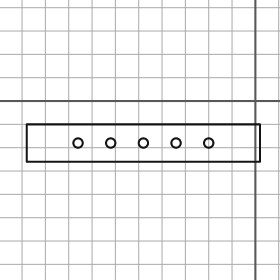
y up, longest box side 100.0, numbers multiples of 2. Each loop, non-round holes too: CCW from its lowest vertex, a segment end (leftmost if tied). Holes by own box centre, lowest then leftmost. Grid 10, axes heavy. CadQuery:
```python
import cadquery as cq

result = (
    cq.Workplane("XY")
    .moveTo(-98.0, -26.0)
    .lineTo(2.0, -26.0)
    .lineTo(2.0, -10.0)
    .lineTo(-98.0, -10.0)
    .close()
    .moveTo(-76.0, -18.0)
    .circle(2.0)
    .moveTo(-62.0, -18.0)
    .circle(2.0)
    .moveTo(-48.0, -18.0)
    .circle(2.0)
    .moveTo(-34.0, -18.0)
    .circle(2.0)
    .moveTo(-20.0, -18.0)
    .circle(2.0)
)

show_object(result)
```